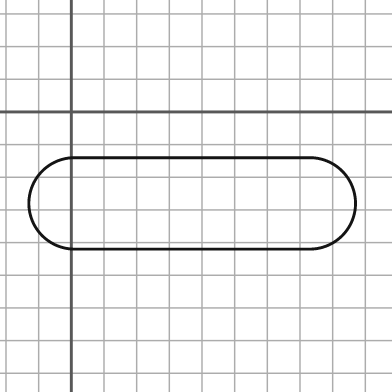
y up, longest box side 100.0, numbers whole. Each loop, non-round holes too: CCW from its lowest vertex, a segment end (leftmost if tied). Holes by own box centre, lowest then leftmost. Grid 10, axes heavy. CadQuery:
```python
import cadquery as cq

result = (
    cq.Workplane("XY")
    .moveTo(1.0, -42.0)
    .lineTo(73.0, -42.0)
    .threePointArc((87.0, -28.0), (73.0, -14.0))
    .lineTo(1.0, -14.0)
    .threePointArc((-13.0, -28.0), (1.0, -42.0))
    .close()
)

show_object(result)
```